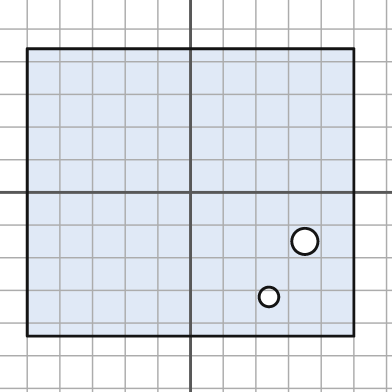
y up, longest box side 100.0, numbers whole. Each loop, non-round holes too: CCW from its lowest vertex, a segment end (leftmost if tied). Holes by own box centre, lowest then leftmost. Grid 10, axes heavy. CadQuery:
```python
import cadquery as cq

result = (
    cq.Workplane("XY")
    .moveTo(-50.0, -44.0)
    .lineTo(50.0, -44.0)
    .lineTo(50.0, 44.0)
    .lineTo(-50.0, 44.0)
    .close()
    .moveTo(24.0, -32.0)
    .circle(3.0)
    .moveTo(35.0, -15.0)
    .circle(4.0)
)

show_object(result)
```